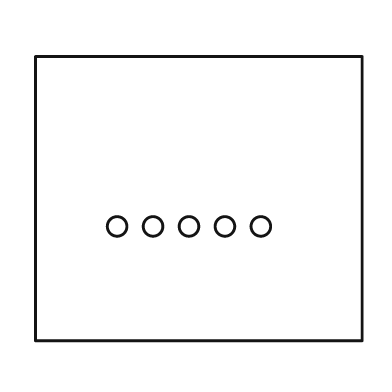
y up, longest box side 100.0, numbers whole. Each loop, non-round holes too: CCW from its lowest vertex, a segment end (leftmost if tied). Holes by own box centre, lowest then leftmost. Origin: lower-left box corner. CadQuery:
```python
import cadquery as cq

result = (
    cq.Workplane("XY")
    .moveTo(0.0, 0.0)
    .lineTo(100.0, 0.0)
    .lineTo(100.0, 87.0)
    .lineTo(0.0, 87.0)
    .close()
    .moveTo(25.0, 35.0)
    .circle(3.0)
    .moveTo(36.0, 35.0)
    .circle(3.0)
    .moveTo(47.0, 35.0)
    .circle(3.0)
    .moveTo(58.0, 35.0)
    .circle(3.0)
    .moveTo(69.0, 35.0)
    .circle(3.0)
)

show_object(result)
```